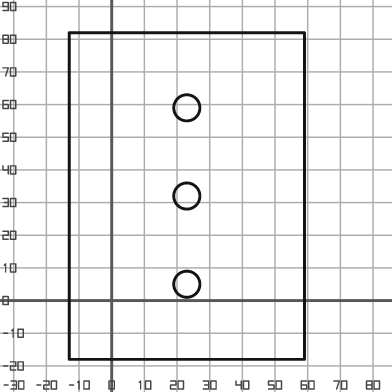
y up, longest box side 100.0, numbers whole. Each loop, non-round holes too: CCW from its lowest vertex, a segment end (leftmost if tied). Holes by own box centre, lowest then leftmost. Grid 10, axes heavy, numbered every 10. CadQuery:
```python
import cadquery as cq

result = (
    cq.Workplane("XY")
    .moveTo(-13.0, -18.0)
    .lineTo(59.0, -18.0)
    .lineTo(59.0, 82.0)
    .lineTo(-13.0, 82.0)
    .close()
    .moveTo(23.0, 5.0)
    .circle(4.0)
    .moveTo(23.0, 32.0)
    .circle(4.0)
    .moveTo(23.0, 59.0)
    .circle(4.0)
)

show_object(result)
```